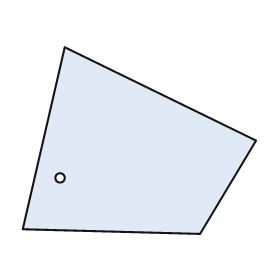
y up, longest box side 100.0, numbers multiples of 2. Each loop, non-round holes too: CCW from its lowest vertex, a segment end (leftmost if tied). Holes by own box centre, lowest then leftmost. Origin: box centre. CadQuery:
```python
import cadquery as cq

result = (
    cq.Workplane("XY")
    .moveTo(26.0, -40.0)
    .lineTo(50.0, 0.0)
    .lineTo(-32.0, 40.0)
    .lineTo(-50.0, -38.0)
    .close()
    .moveTo(-34.0, -16.0)
    .circle(2.0)
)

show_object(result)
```